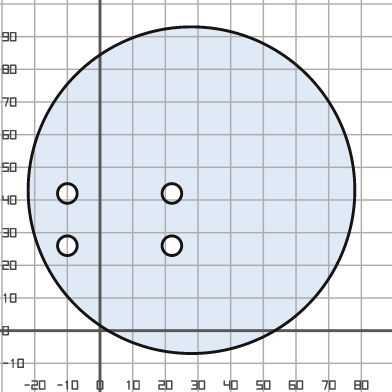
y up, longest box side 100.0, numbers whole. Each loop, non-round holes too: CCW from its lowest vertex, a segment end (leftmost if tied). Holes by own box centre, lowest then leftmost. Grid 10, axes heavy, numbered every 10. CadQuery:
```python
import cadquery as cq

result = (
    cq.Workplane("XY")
    .moveTo(28.0, 43.0)
    .circle(50.0)
    .moveTo(-10.0, 26.0)
    .circle(3.0)
    .moveTo(22.0, 26.0)
    .circle(3.0)
    .moveTo(-10.0, 42.0)
    .circle(3.0)
    .moveTo(22.0, 42.0)
    .circle(3.0)
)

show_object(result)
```